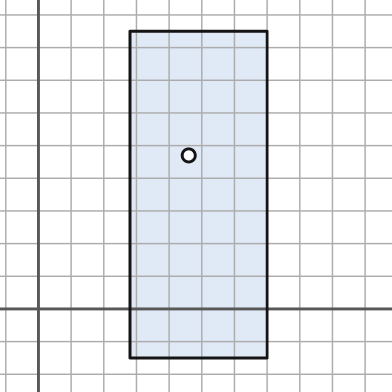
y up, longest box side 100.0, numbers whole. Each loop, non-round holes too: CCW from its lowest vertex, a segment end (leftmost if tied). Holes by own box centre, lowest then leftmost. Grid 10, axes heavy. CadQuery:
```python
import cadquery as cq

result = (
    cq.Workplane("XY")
    .moveTo(28.0, -15.0)
    .lineTo(70.0, -15.0)
    .lineTo(70.0, 85.0)
    .lineTo(28.0, 85.0)
    .close()
    .moveTo(46.0, 47.0)
    .circle(2.0)
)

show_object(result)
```